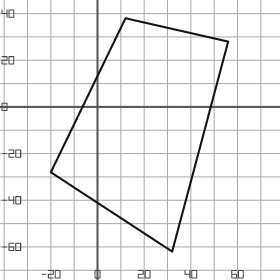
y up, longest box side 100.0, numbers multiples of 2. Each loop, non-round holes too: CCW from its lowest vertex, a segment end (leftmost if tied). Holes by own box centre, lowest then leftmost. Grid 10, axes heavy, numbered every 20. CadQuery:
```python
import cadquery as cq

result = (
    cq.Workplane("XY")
    .moveTo(32.0, -62.0)
    .lineTo(56.0, 28.0)
    .lineTo(12.0, 38.0)
    .lineTo(-20.0, -28.0)
    .close()
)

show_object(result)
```